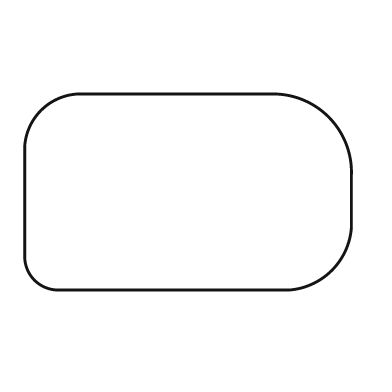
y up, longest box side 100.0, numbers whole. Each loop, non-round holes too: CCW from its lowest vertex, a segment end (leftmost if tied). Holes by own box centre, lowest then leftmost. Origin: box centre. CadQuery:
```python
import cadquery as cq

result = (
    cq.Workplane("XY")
    .moveTo(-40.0, -30.0)
    .lineTo(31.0, -30.0)
    .threePointArc((44.0, -24.0), (50.0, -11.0))
    .lineTo(50.0, 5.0)
    .threePointArc((43.0, 23.0), (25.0, 30.0))
    .lineTo(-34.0, 30.0)
    .threePointArc((-45.0, 25.0), (-50.0, 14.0))
    .lineTo(-50.0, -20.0)
    .threePointArc((-47.0, -27.0), (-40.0, -30.0))
    .close()
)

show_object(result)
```